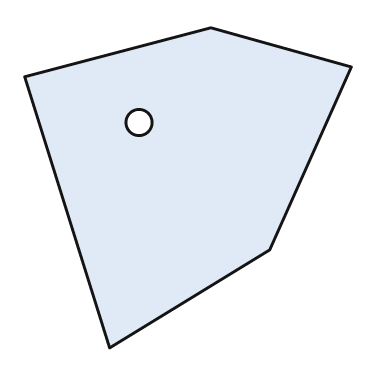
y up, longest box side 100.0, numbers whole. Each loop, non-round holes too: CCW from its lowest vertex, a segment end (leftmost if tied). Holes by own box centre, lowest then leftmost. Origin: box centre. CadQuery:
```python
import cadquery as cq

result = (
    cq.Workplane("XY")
    .moveTo(-24.0, -49.0)
    .lineTo(25.0, -19.0)
    .lineTo(50.0, 37.0)
    .lineTo(7.0, 49.0)
    .lineTo(-50.0, 34.0)
    .close()
    .moveTo(-15.0, 20.0)
    .circle(4.0)
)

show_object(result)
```